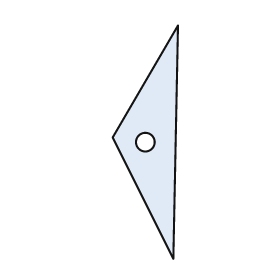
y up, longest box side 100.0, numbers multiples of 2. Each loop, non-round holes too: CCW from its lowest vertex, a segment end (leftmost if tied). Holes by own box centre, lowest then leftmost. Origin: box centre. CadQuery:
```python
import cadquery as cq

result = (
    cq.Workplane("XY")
    .moveTo(12.0, -50.0)
    .lineTo(14.0, 50.0)
    .lineTo(-14.0, 2.0)
    .close()
    .moveTo(0.0, 0.0)
    .circle(4.0)
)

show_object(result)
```